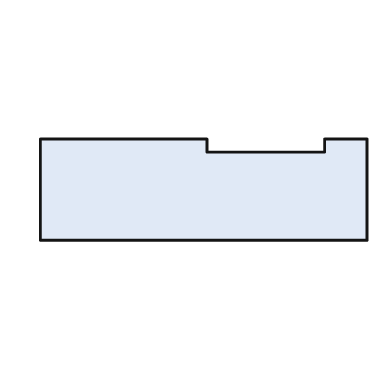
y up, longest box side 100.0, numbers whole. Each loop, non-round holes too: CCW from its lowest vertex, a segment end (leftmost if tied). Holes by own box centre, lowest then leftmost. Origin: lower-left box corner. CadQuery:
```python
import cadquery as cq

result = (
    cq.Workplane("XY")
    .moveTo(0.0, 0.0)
    .lineTo(100.0, 0.0)
    .lineTo(100.0, 31.0)
    .lineTo(87.0, 31.0)
    .lineTo(87.0, 27.0)
    .lineTo(51.0, 27.0)
    .lineTo(51.0, 31.0)
    .lineTo(0.0, 31.0)
    .close()
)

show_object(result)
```